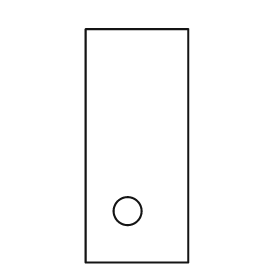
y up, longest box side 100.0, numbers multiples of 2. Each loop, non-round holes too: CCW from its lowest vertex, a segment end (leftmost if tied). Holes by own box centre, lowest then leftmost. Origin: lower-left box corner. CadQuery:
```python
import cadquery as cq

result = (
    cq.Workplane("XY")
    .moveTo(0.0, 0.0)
    .lineTo(44.0, 0.0)
    .lineTo(44.0, 100.0)
    .lineTo(0.0, 100.0)
    .close()
    .moveTo(18.0, 22.0)
    .circle(6.0)
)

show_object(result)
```